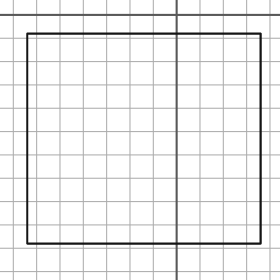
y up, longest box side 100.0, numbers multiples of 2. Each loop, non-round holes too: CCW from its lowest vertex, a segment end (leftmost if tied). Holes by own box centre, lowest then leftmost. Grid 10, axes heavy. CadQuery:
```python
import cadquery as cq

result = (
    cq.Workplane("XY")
    .moveTo(-64.0, -98.0)
    .lineTo(36.0, -98.0)
    .lineTo(36.0, -8.0)
    .lineTo(-64.0, -8.0)
    .close()
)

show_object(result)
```